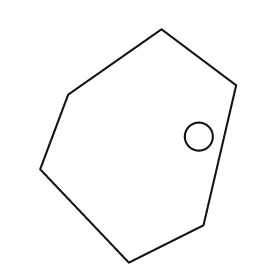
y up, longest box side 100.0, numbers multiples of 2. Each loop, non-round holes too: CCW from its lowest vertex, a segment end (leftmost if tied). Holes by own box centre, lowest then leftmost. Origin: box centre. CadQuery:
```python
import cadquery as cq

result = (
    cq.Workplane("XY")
    .moveTo(-4.0, -50.0)
    .lineTo(28.0, -34.0)
    .lineTo(42.0, 26.0)
    .lineTo(10.0, 50.0)
    .lineTo(-30.0, 22.0)
    .lineTo(-42.0, -10.0)
    .close()
    .moveTo(26.0, 4.0)
    .circle(6.0)
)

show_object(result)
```